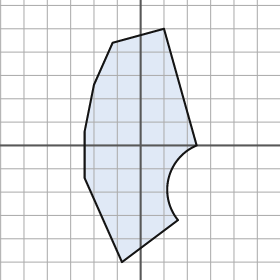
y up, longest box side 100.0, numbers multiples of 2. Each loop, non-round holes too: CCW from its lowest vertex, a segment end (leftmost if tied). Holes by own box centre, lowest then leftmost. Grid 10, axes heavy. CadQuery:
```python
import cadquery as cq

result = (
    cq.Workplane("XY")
    .moveTo(-8.0, -50.0)
    .lineTo(16.0, -32.0)
    .threePointArc((12.0, -14.0), (24.0, 0.0))
    .lineTo(10.0, 50.0)
    .lineTo(-12.0, 44.0)
    .lineTo(-20.0, 26.0)
    .lineTo(-24.0, 6.0)
    .lineTo(-24.0, -14.0)
    .close()
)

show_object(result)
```